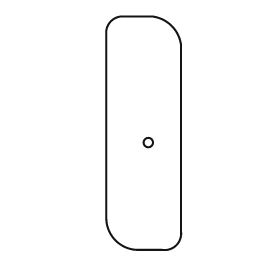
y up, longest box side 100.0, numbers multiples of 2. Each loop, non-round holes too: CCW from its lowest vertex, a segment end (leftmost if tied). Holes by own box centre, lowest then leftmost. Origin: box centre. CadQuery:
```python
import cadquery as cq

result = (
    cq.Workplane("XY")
    .moveTo(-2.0, -50.0)
    .lineTo(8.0, -50.0)
    .threePointArc((14.0, -48.0), (16.0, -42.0))
    .lineTo(16.0, 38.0)
    .threePointArc((12.0, 46.0), (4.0, 50.0))
    .lineTo(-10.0, 50.0)
    .threePointArc((-14.0, 48.0), (-16.0, 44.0))
    .lineTo(-16.0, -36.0)
    .threePointArc((-12.0, -46.0), (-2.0, -50.0))
    .close()
    .moveTo(2.0, -4.0)
    .circle(2.0)
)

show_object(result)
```